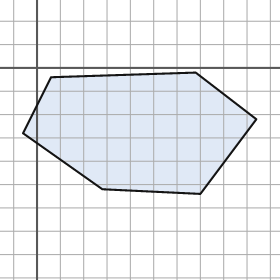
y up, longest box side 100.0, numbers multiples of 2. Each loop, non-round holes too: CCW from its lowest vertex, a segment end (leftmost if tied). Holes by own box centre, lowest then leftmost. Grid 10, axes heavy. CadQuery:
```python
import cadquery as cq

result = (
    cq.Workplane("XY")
    .moveTo(70.0, -54.0)
    .lineTo(94.0, -22.0)
    .lineTo(68.0, -2.0)
    .lineTo(6.0, -4.0)
    .lineTo(-6.0, -28.0)
    .lineTo(28.0, -52.0)
    .close()
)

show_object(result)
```